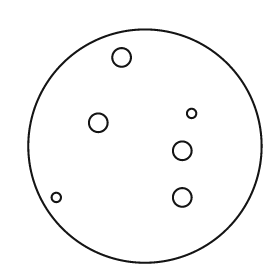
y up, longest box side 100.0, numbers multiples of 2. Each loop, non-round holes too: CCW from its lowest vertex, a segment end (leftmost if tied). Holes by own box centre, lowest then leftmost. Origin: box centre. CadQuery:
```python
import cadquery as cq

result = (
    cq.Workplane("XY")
    .moveTo(0.0, 0.0)
    .circle(50.0)
    .moveTo(-38.0, -22.0)
    .circle(2.0)
    .moveTo(16.0, -22.0)
    .circle(4.0)
    .moveTo(16.0, -2.0)
    .circle(4.0)
    .moveTo(-20.0, 10.0)
    .circle(4.0)
    .moveTo(20.0, 14.0)
    .circle(2.0)
    .moveTo(-10.0, 38.0)
    .circle(4.0)
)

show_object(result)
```